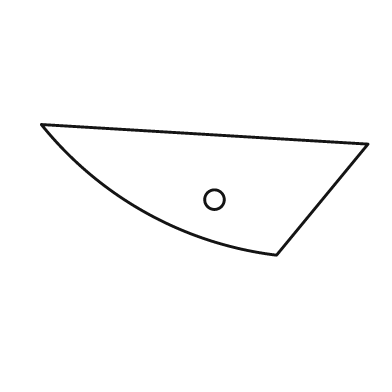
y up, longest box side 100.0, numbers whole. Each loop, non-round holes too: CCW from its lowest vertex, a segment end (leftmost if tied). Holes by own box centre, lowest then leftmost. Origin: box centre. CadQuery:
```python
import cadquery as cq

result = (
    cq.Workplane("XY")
    .moveTo(22.0, -20.0)
    .lineTo(50.0, 14.0)
    .lineTo(-50.0, 20.0)
    .threePointArc((-18.0, -7.0), (22.0, -20.0))
    .close()
    .moveTo(3.0, -3.0)
    .circle(3.0)
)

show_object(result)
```